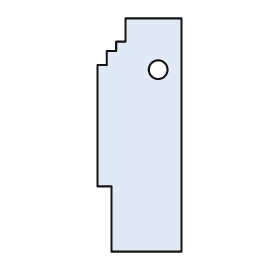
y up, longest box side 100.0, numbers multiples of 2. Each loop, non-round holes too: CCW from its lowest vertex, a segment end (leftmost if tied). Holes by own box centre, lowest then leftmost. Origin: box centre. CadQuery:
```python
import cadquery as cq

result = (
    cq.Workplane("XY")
    .moveTo(-12.0, -50.0)
    .lineTo(18.0, -50.0)
    .lineTo(18.0, 50.0)
    .lineTo(-6.0, 50.0)
    .lineTo(-6.0, 40.0)
    .lineTo(-10.0, 40.0)
    .lineTo(-10.0, 36.0)
    .lineTo(-14.0, 36.0)
    .lineTo(-14.0, 30.0)
    .lineTo(-18.0, 30.0)
    .lineTo(-18.0, -22.0)
    .lineTo(-12.0, -22.0)
    .close()
    .moveTo(8.0, 28.0)
    .circle(4.0)
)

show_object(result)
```